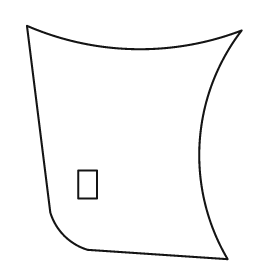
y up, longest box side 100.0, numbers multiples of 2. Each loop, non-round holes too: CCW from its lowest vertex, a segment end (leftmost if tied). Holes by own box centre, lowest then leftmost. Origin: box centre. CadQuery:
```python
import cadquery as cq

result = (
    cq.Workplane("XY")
    .moveTo(40.0, -50.0)
    .threePointArc((28.0, 0.0), (46.0, 48.0))
    .threePointArc((0.0, 40.0), (-46.0, 50.0))
    .lineTo(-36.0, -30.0)
    .threePointArc((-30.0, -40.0), (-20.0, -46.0))
    .close()
    .moveTo(-24.0, -24.0)
    .lineTo(-16.0, -24.0)
    .lineTo(-16.0, -12.0)
    .lineTo(-24.0, -12.0)
    .close()
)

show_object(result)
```